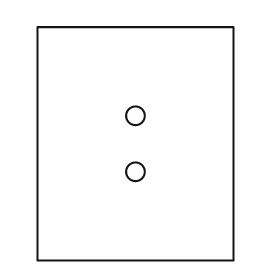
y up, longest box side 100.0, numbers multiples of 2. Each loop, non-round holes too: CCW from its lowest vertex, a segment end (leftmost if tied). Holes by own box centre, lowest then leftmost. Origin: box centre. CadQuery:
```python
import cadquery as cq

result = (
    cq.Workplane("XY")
    .moveTo(-42.0, -50.0)
    .lineTo(42.0, -50.0)
    .lineTo(42.0, 50.0)
    .lineTo(-42.0, 50.0)
    .close()
    .moveTo(0.0, -12.0)
    .circle(4.0)
    .moveTo(0.0, 12.0)
    .circle(4.0)
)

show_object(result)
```